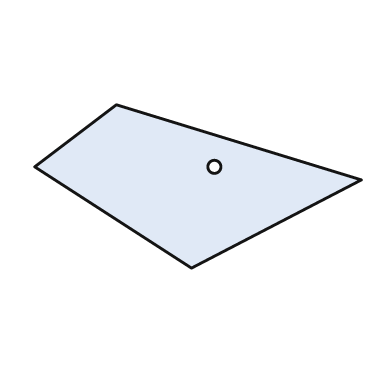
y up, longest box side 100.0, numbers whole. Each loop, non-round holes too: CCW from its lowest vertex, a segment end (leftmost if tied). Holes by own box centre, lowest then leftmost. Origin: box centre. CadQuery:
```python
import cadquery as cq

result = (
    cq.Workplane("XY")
    .moveTo(-2.0, -25.0)
    .lineTo(50.0, 2.0)
    .lineTo(-25.0, 25.0)
    .lineTo(-50.0, 6.0)
    .close()
    .moveTo(5.0, 6.0)
    .circle(2.0)
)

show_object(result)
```